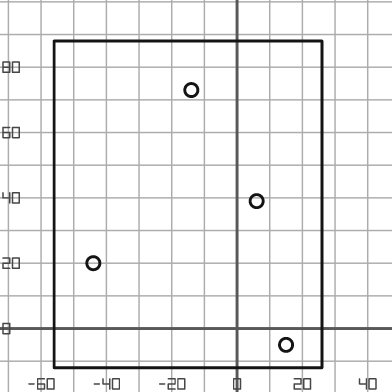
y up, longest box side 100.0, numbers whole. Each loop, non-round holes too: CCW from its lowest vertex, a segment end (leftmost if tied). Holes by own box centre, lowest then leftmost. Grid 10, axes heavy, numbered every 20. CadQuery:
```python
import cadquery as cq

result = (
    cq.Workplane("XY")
    .moveTo(-56.0, -12.0)
    .lineTo(26.0, -12.0)
    .lineTo(26.0, 88.0)
    .lineTo(-56.0, 88.0)
    .close()
    .moveTo(15.0, -5.0)
    .circle(2.0)
    .moveTo(-44.0, 20.0)
    .circle(2.0)
    .moveTo(6.0, 39.0)
    .circle(2.0)
    .moveTo(-14.0, 73.0)
    .circle(2.0)
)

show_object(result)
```